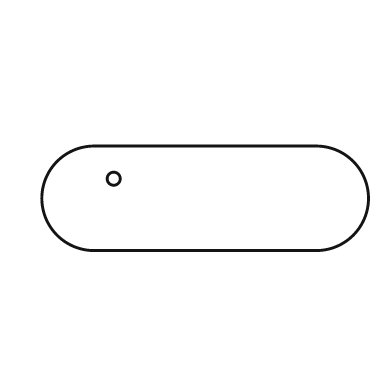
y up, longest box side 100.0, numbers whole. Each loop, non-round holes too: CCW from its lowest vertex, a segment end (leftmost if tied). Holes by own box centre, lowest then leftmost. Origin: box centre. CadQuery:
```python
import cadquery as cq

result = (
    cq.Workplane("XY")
    .moveTo(-34.0, -16.0)
    .lineTo(34.0, -16.0)
    .threePointArc((50.0, 0.0), (34.0, 16.0))
    .lineTo(-34.0, 16.0)
    .threePointArc((-50.0, 0.0), (-34.0, -16.0))
    .close()
    .moveTo(-28.0, 6.0)
    .circle(2.0)
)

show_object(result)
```